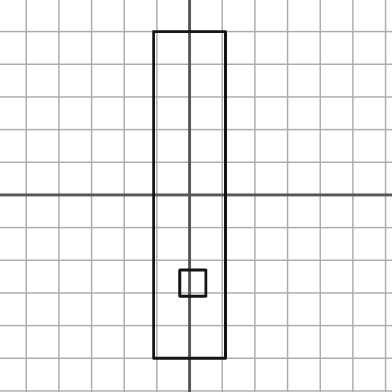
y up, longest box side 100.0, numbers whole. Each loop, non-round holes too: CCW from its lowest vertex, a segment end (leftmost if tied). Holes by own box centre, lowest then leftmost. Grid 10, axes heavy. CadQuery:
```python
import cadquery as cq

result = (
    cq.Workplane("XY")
    .moveTo(-11.0, -50.0)
    .lineTo(11.0, -50.0)
    .lineTo(11.0, 50.0)
    .lineTo(-11.0, 50.0)
    .close()
    .moveTo(-3.0, -31.0)
    .lineTo(5.0, -31.0)
    .lineTo(5.0, -23.0)
    .lineTo(-3.0, -23.0)
    .close()
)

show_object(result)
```